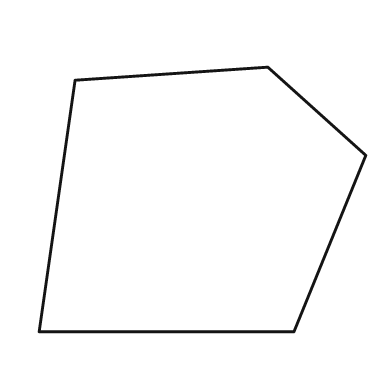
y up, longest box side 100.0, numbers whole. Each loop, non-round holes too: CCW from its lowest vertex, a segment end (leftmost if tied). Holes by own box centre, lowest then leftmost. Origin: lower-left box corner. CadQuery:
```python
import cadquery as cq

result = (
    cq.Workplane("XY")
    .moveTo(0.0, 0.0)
    .lineTo(78.0, 0.0)
    .lineTo(100.0, 54.0)
    .lineTo(70.0, 81.0)
    .lineTo(11.0, 77.0)
    .close()
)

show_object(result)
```